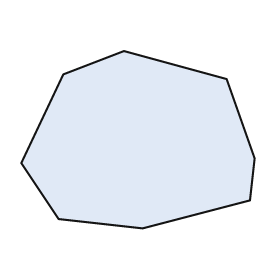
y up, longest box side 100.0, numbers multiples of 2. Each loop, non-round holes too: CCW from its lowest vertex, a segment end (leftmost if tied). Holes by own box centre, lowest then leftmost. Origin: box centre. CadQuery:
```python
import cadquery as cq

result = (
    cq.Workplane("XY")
    .moveTo(2.0, -38.0)
    .lineTo(48.0, -26.0)
    .lineTo(50.0, -8.0)
    .lineTo(38.0, 26.0)
    .lineTo(-6.0, 38.0)
    .lineTo(-32.0, 28.0)
    .lineTo(-50.0, -10.0)
    .lineTo(-34.0, -34.0)
    .close()
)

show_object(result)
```